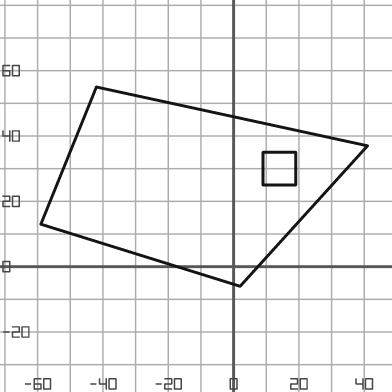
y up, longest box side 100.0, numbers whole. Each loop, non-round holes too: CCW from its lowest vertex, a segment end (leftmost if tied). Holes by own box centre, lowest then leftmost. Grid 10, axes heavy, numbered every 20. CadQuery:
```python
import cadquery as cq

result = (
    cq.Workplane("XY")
    .moveTo(2.0, -6.0)
    .lineTo(41.0, 37.0)
    .lineTo(-42.0, 55.0)
    .lineTo(-59.0, 13.0)
    .close()
    .moveTo(9.0, 25.0)
    .lineTo(19.0, 25.0)
    .lineTo(19.0, 35.0)
    .lineTo(9.0, 35.0)
    .close()
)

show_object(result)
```